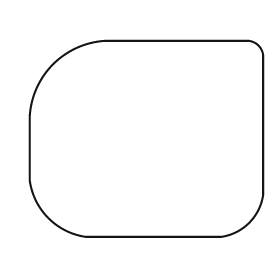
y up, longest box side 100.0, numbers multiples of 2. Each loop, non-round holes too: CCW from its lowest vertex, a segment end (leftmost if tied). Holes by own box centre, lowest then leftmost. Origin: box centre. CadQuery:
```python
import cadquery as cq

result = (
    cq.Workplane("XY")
    .moveTo(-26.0, -42.0)
    .lineTo(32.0, -42.0)
    .threePointArc((44.0, -36.0), (50.0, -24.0))
    .lineTo(50.0, 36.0)
    .threePointArc((48.0, 40.0), (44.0, 42.0))
    .lineTo(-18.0, 42.0)
    .threePointArc((-40.0, 32.0), (-50.0, 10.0))
    .lineTo(-50.0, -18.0)
    .threePointArc((-42.0, -34.0), (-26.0, -42.0))
    .close()
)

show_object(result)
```